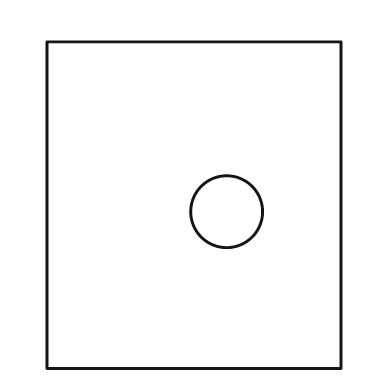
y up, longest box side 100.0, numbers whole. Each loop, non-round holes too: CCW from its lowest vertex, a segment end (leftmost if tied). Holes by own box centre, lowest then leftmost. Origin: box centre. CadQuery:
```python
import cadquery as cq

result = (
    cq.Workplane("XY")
    .moveTo(-45.0, -50.0)
    .lineTo(45.0, -50.0)
    .lineTo(45.0, 50.0)
    .lineTo(-45.0, 50.0)
    .close()
    .moveTo(10.0, -2.0)
    .circle(11.0)
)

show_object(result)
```